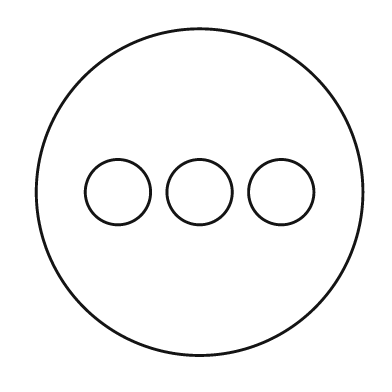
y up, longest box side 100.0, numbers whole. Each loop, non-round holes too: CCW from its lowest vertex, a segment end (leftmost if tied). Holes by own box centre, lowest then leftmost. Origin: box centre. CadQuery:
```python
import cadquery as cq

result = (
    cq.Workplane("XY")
    .moveTo(0.0, 0.0)
    .circle(50.0)
    .moveTo(-25.0, 0.0)
    .circle(10.0)
    .moveTo(0.0, 0.0)
    .circle(10.0)
    .moveTo(25.0, 0.0)
    .circle(10.0)
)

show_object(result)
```